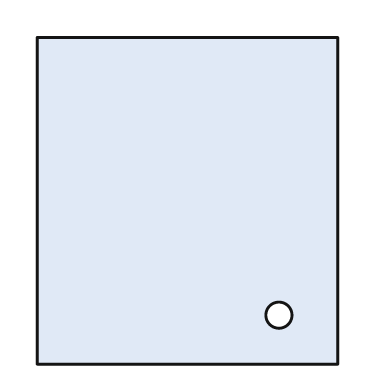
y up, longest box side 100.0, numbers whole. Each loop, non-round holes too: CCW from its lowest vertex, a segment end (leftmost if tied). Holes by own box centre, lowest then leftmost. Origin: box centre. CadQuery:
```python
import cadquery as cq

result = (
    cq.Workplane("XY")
    .moveTo(-46.0, -50.0)
    .lineTo(46.0, -50.0)
    .lineTo(46.0, 50.0)
    .lineTo(-46.0, 50.0)
    .close()
    .moveTo(28.0, -35.0)
    .circle(4.0)
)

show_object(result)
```